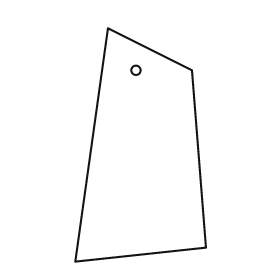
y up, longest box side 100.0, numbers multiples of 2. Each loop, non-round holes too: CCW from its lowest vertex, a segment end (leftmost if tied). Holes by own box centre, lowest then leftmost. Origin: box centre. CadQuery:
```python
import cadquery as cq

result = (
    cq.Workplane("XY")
    .moveTo(-28.0, -50.0)
    .lineTo(28.0, -44.0)
    .lineTo(22.0, 32.0)
    .lineTo(-14.0, 50.0)
    .close()
    .moveTo(-2.0, 32.0)
    .circle(2.0)
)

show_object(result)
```